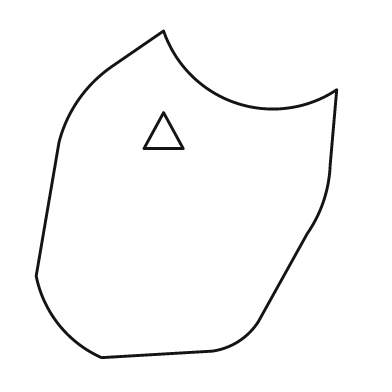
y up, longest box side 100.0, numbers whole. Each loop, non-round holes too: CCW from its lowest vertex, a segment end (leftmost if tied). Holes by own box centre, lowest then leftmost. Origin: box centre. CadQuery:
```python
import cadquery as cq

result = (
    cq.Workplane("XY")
    .moveTo(-26.0, -50.0)
    .lineTo(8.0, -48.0)
    .threePointArc((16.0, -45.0), (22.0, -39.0))
    .lineTo(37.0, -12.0)
    .threePointArc((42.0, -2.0), (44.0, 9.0))
    .lineTo(46.0, 32.0)
    .threePointArc((15.0, 28.0), (-7.0, 50.0))
    .lineTo(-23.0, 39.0)
    .threePointArc((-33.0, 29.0), (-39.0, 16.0))
    .lineTo(-46.0, -25.0)
    .threePointArc((-39.0, -40.0), (-26.0, -50.0))
    .close()
    .moveTo(-13.0, 14.0)
    .lineTo(-1.0, 14.0)
    .lineTo(-7.0, 25.0)
    .close()
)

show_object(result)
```